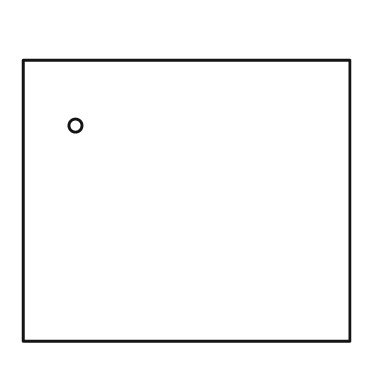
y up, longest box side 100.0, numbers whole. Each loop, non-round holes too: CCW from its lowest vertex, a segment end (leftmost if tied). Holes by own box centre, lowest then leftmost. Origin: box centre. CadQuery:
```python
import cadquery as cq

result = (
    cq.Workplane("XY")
    .moveTo(-50.0, -43.0)
    .lineTo(50.0, -43.0)
    .lineTo(50.0, 43.0)
    .lineTo(-50.0, 43.0)
    .close()
    .moveTo(-34.0, 23.0)
    .circle(2.0)
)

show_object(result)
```